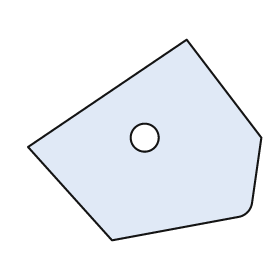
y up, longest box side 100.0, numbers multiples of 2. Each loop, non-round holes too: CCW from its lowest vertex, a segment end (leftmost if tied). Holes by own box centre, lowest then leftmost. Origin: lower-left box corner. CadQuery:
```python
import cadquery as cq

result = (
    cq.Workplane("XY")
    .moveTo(36.0, 0.0)
    .lineTo(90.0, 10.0)
    .threePointArc((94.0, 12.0), (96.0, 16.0))
    .lineTo(100.0, 44.0)
    .lineTo(68.0, 86.0)
    .lineTo(0.0, 40.0)
    .close()
    .moveTo(50.0, 44.0)
    .circle(6.0)
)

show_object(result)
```